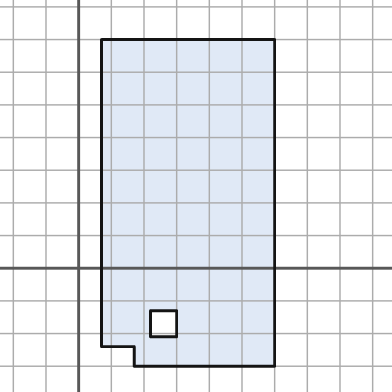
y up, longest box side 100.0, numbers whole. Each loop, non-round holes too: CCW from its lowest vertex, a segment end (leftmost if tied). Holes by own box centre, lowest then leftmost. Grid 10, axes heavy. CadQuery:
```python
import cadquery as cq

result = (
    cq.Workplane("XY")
    .moveTo(17.0, -30.0)
    .lineTo(60.0, -30.0)
    .lineTo(60.0, 70.0)
    .lineTo(7.0, 70.0)
    .lineTo(7.0, -24.0)
    .lineTo(17.0, -24.0)
    .close()
    .moveTo(22.0, -21.0)
    .lineTo(30.0, -21.0)
    .lineTo(30.0, -13.0)
    .lineTo(22.0, -13.0)
    .close()
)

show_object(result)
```